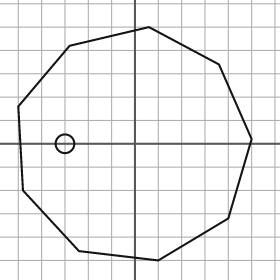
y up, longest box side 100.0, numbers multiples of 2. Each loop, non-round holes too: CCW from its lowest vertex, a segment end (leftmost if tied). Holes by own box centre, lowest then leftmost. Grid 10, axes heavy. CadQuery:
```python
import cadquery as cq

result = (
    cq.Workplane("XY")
    .moveTo(10.0, -50.0)
    .lineTo(40.0, -32.0)
    .lineTo(50.0, 2.0)
    .lineTo(36.0, 34.0)
    .lineTo(6.0, 50.0)
    .lineTo(-28.0, 42.0)
    .lineTo(-50.0, 16.0)
    .lineTo(-48.0, -20.0)
    .lineTo(-24.0, -46.0)
    .close()
    .moveTo(-30.0, 0.0)
    .circle(4.0)
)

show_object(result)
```